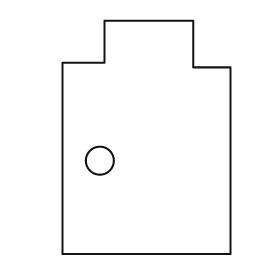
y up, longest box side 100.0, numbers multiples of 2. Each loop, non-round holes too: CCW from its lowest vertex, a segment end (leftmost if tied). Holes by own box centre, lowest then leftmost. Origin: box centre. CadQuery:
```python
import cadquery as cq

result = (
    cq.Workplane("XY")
    .moveTo(-36.0, -50.0)
    .lineTo(36.0, -50.0)
    .lineTo(36.0, 30.0)
    .lineTo(20.0, 30.0)
    .lineTo(20.0, 50.0)
    .lineTo(-18.0, 50.0)
    .lineTo(-18.0, 32.0)
    .lineTo(-36.0, 32.0)
    .close()
    .moveTo(-20.0, -10.0)
    .circle(6.0)
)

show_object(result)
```